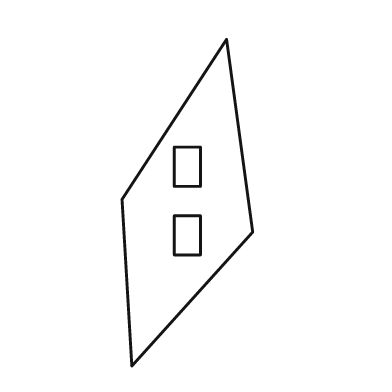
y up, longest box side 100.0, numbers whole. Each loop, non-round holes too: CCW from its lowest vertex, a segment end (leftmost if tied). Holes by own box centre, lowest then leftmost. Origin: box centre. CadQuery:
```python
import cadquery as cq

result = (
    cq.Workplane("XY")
    .moveTo(-17.0, -50.0)
    .lineTo(20.0, -9.0)
    .lineTo(12.0, 50.0)
    .lineTo(-20.0, 1.0)
    .close()
    .moveTo(-4.0, -16.0)
    .lineTo(4.0, -16.0)
    .lineTo(4.0, -4.0)
    .lineTo(-4.0, -4.0)
    .close()
    .moveTo(-4.0, 5.0)
    .lineTo(4.0, 5.0)
    .lineTo(4.0, 17.0)
    .lineTo(-4.0, 17.0)
    .close()
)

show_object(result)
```